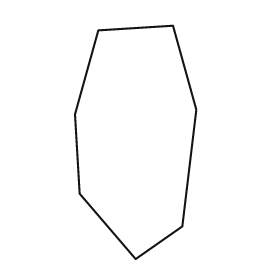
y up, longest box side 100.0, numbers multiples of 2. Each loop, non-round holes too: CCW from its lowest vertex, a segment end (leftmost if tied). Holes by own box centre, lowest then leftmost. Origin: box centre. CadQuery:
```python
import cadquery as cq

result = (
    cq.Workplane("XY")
    .moveTo(0.0, -50.0)
    .lineTo(20.0, -36.0)
    .lineTo(26.0, 14.0)
    .lineTo(16.0, 50.0)
    .lineTo(-16.0, 48.0)
    .lineTo(-26.0, 12.0)
    .lineTo(-24.0, -22.0)
    .close()
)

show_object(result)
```